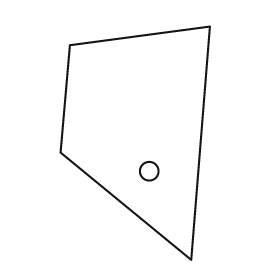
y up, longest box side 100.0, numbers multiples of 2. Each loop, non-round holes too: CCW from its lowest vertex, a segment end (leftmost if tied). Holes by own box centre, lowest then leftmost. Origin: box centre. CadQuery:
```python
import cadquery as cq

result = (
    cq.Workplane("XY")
    .moveTo(24.0, -50.0)
    .lineTo(32.0, 50.0)
    .lineTo(-28.0, 42.0)
    .lineTo(-32.0, -4.0)
    .close()
    .moveTo(6.0, -12.0)
    .circle(4.0)
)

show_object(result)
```